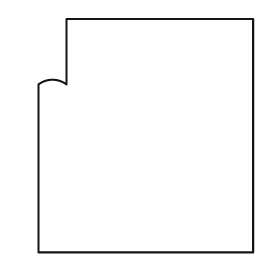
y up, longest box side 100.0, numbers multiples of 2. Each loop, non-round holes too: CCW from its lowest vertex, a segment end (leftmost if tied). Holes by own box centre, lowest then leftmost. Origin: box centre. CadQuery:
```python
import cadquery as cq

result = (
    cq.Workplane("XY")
    .moveTo(-46.0, -50.0)
    .lineTo(46.0, -50.0)
    .lineTo(46.0, 50.0)
    .lineTo(-34.0, 50.0)
    .lineTo(-34.0, 22.0)
    .threePointArc((-40.0, 24.0), (-46.0, 22.0))
    .close()
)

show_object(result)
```